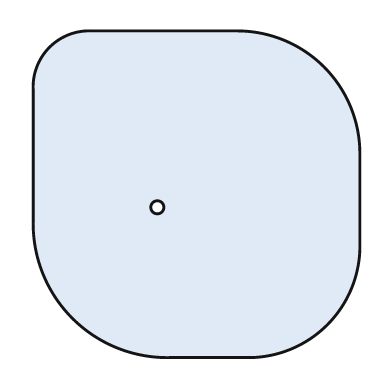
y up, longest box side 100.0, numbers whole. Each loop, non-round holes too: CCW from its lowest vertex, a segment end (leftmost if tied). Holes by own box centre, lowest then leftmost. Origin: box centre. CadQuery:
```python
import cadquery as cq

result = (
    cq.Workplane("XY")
    .moveTo(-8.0, -50.0)
    .lineTo(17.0, -50.0)
    .threePointArc((40.0, -40.0), (50.0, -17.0))
    .lineTo(50.0, 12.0)
    .threePointArc((39.0, 39.0), (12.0, 50.0))
    .lineTo(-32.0, 50.0)
    .threePointArc((-45.0, 45.0), (-50.0, 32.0))
    .lineTo(-50.0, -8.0)
    .threePointArc((-38.0, -38.0), (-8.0, -50.0))
    .close()
    .moveTo(-12.0, -4.0)
    .circle(2.0)
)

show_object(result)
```